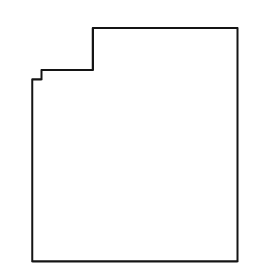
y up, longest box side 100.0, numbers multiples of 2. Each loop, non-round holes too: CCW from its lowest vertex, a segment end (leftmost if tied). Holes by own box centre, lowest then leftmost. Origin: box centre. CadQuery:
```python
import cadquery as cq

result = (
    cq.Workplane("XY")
    .moveTo(-44.0, -50.0)
    .lineTo(44.0, -50.0)
    .lineTo(44.0, 50.0)
    .lineTo(-18.0, 50.0)
    .lineTo(-18.0, 32.0)
    .lineTo(-40.0, 32.0)
    .lineTo(-40.0, 28.0)
    .lineTo(-44.0, 28.0)
    .close()
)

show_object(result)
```